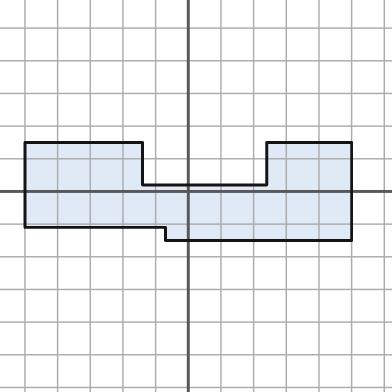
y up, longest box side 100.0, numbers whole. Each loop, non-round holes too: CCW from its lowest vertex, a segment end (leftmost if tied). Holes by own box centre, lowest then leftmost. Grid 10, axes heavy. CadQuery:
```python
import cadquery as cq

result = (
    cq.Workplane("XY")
    .moveTo(-7.0, -15.0)
    .lineTo(50.0, -15.0)
    .lineTo(50.0, 15.0)
    .lineTo(24.0, 15.0)
    .lineTo(24.0, 2.0)
    .lineTo(-14.0, 2.0)
    .lineTo(-14.0, 15.0)
    .lineTo(-50.0, 15.0)
    .lineTo(-50.0, -11.0)
    .lineTo(-7.0, -11.0)
    .close()
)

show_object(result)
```